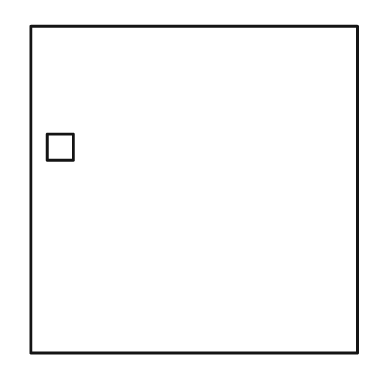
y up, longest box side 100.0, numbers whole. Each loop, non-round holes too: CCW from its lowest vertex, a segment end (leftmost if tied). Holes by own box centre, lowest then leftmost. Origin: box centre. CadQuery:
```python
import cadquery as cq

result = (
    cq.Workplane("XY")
    .moveTo(-50.0, -50.0)
    .lineTo(50.0, -50.0)
    .lineTo(50.0, 50.0)
    .lineTo(-50.0, 50.0)
    .close()
    .moveTo(-45.0, 9.0)
    .lineTo(-37.0, 9.0)
    .lineTo(-37.0, 17.0)
    .lineTo(-45.0, 17.0)
    .close()
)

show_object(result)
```